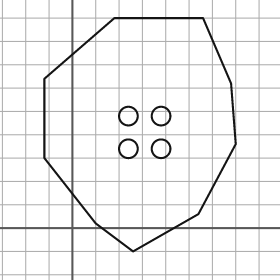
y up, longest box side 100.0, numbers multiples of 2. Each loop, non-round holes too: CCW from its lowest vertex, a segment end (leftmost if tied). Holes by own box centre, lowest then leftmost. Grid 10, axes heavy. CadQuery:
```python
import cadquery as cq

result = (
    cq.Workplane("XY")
    .moveTo(26.0, -10.0)
    .lineTo(54.0, 6.0)
    .lineTo(70.0, 36.0)
    .lineTo(68.0, 62.0)
    .lineTo(56.0, 90.0)
    .lineTo(18.0, 90.0)
    .lineTo(-12.0, 64.0)
    .lineTo(-12.0, 30.0)
    .lineTo(10.0, 2.0)
    .close()
    .moveTo(24.0, 34.0)
    .circle(4.0)
    .moveTo(38.0, 34.0)
    .circle(4.0)
    .moveTo(24.0, 48.0)
    .circle(4.0)
    .moveTo(38.0, 48.0)
    .circle(4.0)
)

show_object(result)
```